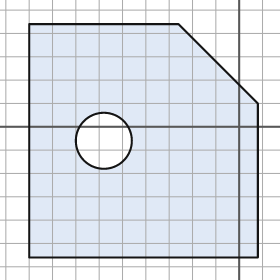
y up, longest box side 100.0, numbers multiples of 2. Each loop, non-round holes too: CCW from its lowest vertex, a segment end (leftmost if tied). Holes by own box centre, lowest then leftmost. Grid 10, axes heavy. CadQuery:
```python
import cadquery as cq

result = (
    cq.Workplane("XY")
    .moveTo(-90.0, -56.0)
    .lineTo(8.0, -56.0)
    .lineTo(8.0, 10.0)
    .lineTo(-26.0, 44.0)
    .lineTo(-90.0, 44.0)
    .close()
    .moveTo(-58.0, -6.0)
    .circle(12.0)
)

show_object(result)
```